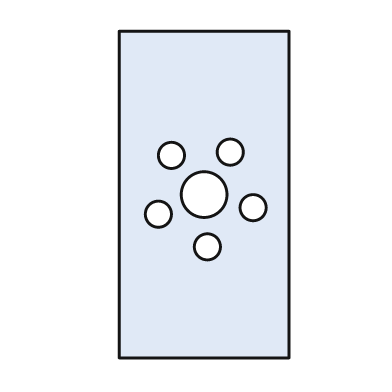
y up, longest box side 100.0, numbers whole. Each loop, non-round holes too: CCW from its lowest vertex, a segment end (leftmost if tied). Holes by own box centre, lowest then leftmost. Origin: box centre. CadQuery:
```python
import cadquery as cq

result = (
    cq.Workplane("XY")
    .moveTo(-26.0, -50.0)
    .lineTo(26.0, -50.0)
    .lineTo(26.0, 50.0)
    .lineTo(-26.0, 50.0)
    .close()
    .moveTo(1.0, -16.0)
    .circle(4.0)
    .moveTo(-14.0, -6.0)
    .circle(4.0)
    .moveTo(15.0, -4.0)
    .circle(4.0)
    .moveTo(0.0, 0.0)
    .circle(7.0)
    .moveTo(-10.0, 12.0)
    .circle(4.0)
    .moveTo(8.0, 13.0)
    .circle(4.0)
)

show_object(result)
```